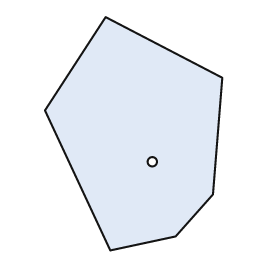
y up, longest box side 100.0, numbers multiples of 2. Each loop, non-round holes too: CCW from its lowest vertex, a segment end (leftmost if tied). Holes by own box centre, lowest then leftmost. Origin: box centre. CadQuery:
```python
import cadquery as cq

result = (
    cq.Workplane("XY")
    .moveTo(-10.0, -50.0)
    .lineTo(18.0, -44.0)
    .lineTo(34.0, -26.0)
    .lineTo(38.0, 24.0)
    .lineTo(-12.0, 50.0)
    .lineTo(-38.0, 10.0)
    .close()
    .moveTo(8.0, -12.0)
    .circle(2.0)
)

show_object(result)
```